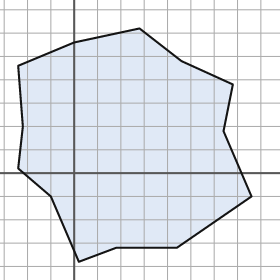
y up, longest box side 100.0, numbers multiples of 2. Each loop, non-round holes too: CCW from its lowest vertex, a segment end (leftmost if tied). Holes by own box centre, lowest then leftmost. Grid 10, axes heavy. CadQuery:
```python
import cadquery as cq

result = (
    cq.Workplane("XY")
    .moveTo(2.0, -38.0)
    .lineTo(18.0, -32.0)
    .lineTo(44.0, -32.0)
    .lineTo(76.0, -10.0)
    .lineTo(64.0, 18.0)
    .lineTo(68.0, 38.0)
    .lineTo(46.0, 48.0)
    .lineTo(28.0, 62.0)
    .lineTo(0.0, 56.0)
    .lineTo(-24.0, 46.0)
    .lineTo(-22.0, 20.0)
    .lineTo(-24.0, 2.0)
    .lineTo(-10.0, -10.0)
    .close()
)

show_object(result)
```